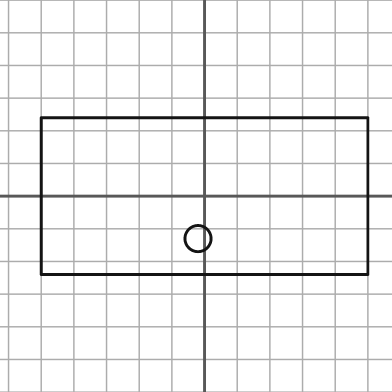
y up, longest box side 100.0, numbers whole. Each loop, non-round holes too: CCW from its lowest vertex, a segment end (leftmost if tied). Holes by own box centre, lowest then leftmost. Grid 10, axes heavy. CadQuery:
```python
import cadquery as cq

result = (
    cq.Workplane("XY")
    .moveTo(-50.0, -24.0)
    .lineTo(50.0, -24.0)
    .lineTo(50.0, 24.0)
    .lineTo(-50.0, 24.0)
    .close()
    .moveTo(-2.0, -13.0)
    .circle(4.0)
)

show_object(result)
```